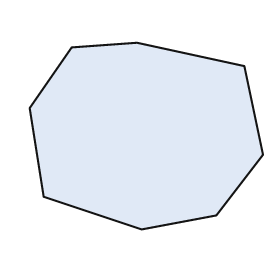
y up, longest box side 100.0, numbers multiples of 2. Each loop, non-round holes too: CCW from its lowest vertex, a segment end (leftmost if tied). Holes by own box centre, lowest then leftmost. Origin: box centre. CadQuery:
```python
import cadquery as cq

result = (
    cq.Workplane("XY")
    .moveTo(-2.0, -40.0)
    .lineTo(30.0, -34.0)
    .lineTo(50.0, -8.0)
    .lineTo(42.0, 30.0)
    .lineTo(-4.0, 40.0)
    .lineTo(-32.0, 38.0)
    .lineTo(-50.0, 12.0)
    .lineTo(-44.0, -26.0)
    .close()
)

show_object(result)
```